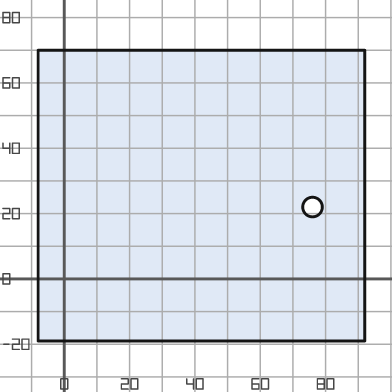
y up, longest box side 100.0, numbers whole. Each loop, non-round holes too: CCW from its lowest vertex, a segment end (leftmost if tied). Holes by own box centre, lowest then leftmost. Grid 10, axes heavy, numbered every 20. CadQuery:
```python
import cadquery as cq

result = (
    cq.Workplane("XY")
    .moveTo(-8.0, -19.0)
    .lineTo(92.0, -19.0)
    .lineTo(92.0, 70.0)
    .lineTo(-8.0, 70.0)
    .close()
    .moveTo(76.0, 22.0)
    .circle(3.0)
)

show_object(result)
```